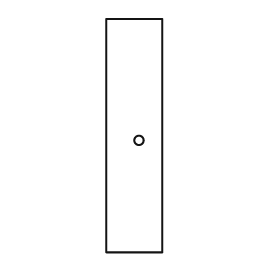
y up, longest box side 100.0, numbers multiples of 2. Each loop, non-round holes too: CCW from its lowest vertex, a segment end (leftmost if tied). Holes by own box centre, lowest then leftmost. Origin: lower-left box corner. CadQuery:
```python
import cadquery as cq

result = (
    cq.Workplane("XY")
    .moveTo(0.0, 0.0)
    .lineTo(24.0, 0.0)
    .lineTo(24.0, 100.0)
    .lineTo(0.0, 100.0)
    .close()
    .moveTo(14.0, 48.0)
    .circle(2.0)
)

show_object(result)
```